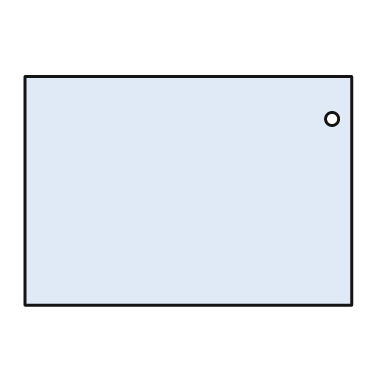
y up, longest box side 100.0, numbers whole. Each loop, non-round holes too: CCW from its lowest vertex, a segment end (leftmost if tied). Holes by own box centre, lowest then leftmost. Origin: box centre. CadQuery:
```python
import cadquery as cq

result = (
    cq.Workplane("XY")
    .moveTo(-50.0, -35.0)
    .lineTo(50.0, -35.0)
    .lineTo(50.0, 35.0)
    .lineTo(-50.0, 35.0)
    .close()
    .moveTo(44.0, 22.0)
    .circle(2.0)
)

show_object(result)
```